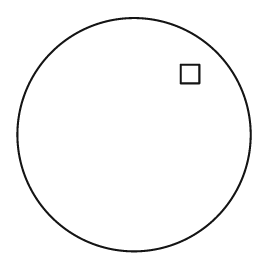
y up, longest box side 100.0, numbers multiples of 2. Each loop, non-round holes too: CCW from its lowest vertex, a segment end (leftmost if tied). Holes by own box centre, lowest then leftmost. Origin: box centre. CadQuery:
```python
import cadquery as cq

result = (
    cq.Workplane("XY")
    .moveTo(0.0, 0.0)
    .circle(50.0)
    .moveTo(20.0, 22.0)
    .lineTo(28.0, 22.0)
    .lineTo(28.0, 30.0)
    .lineTo(20.0, 30.0)
    .close()
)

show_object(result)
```